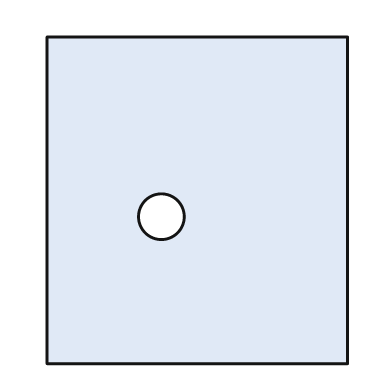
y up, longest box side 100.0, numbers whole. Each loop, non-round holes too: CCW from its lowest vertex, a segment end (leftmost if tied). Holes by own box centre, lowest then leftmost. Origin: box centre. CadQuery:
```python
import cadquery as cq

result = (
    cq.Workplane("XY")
    .moveTo(-46.0, -50.0)
    .lineTo(46.0, -50.0)
    .lineTo(46.0, 50.0)
    .lineTo(-46.0, 50.0)
    .close()
    .moveTo(-11.0, -5.0)
    .circle(7.0)
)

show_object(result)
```